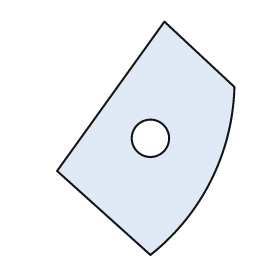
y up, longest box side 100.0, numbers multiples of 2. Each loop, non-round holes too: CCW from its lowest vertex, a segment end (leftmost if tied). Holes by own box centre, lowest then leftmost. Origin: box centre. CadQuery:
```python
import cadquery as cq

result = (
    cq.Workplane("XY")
    .moveTo(2.0, -50.0)
    .threePointArc((28.0, -18.0), (38.0, 22.0))
    .lineTo(8.0, 50.0)
    .lineTo(-38.0, -14.0)
    .close()
    .moveTo(2.0, 0.0)
    .circle(8.0)
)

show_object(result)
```